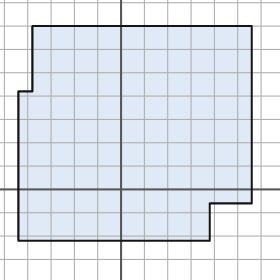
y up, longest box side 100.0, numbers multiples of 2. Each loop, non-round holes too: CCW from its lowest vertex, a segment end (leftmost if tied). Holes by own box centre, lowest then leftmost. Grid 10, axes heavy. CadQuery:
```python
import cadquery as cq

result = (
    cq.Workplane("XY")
    .moveTo(-44.0, -22.0)
    .lineTo(38.0, -22.0)
    .lineTo(38.0, -6.0)
    .lineTo(56.0, -6.0)
    .lineTo(56.0, 70.0)
    .lineTo(-38.0, 70.0)
    .lineTo(-38.0, 42.0)
    .lineTo(-44.0, 42.0)
    .close()
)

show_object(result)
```